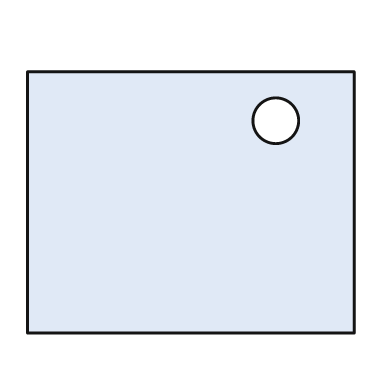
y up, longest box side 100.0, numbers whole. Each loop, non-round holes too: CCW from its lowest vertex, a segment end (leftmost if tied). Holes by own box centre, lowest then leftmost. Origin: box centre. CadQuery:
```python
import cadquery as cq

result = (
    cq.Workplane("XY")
    .moveTo(-50.0, -40.0)
    .lineTo(50.0, -40.0)
    .lineTo(50.0, 40.0)
    .lineTo(-50.0, 40.0)
    .close()
    .moveTo(26.0, 25.0)
    .circle(7.0)
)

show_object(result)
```